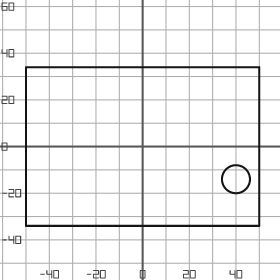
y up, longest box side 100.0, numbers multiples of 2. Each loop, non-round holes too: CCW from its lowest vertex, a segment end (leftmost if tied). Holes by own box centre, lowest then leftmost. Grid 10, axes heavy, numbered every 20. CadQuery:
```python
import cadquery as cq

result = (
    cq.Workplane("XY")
    .moveTo(-50.0, -34.0)
    .lineTo(50.0, -34.0)
    .lineTo(50.0, 34.0)
    .lineTo(-50.0, 34.0)
    .close()
    .moveTo(40.0, -14.0)
    .circle(6.0)
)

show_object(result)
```